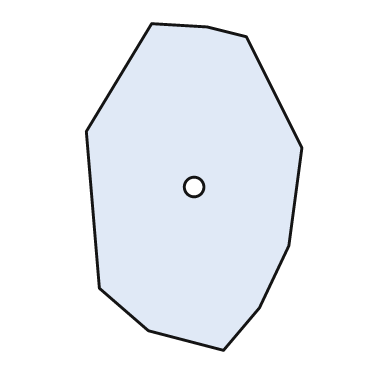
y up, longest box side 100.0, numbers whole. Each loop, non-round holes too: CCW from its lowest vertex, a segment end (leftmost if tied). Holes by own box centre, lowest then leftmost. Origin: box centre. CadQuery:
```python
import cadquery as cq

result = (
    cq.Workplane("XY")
    .moveTo(9.0, -50.0)
    .lineTo(20.0, -37.0)
    .lineTo(29.0, -18.0)
    .lineTo(33.0, 12.0)
    .lineTo(16.0, 46.0)
    .lineTo(4.0, 49.0)
    .lineTo(-13.0, 50.0)
    .lineTo(-33.0, 17.0)
    .lineTo(-29.0, -31.0)
    .lineTo(-14.0, -44.0)
    .close()
    .moveTo(0.0, 0.0)
    .circle(3.0)
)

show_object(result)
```